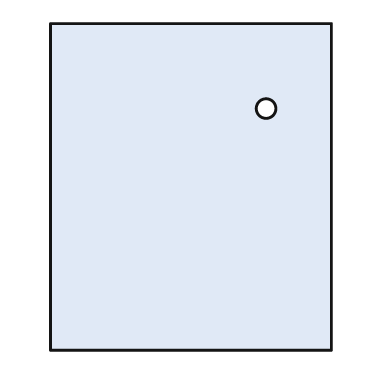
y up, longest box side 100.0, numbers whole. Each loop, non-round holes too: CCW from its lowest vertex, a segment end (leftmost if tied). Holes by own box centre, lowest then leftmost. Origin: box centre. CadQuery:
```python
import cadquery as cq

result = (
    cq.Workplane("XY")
    .moveTo(-43.0, -50.0)
    .lineTo(43.0, -50.0)
    .lineTo(43.0, 50.0)
    .lineTo(-43.0, 50.0)
    .close()
    .moveTo(23.0, 24.0)
    .circle(3.0)
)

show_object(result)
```